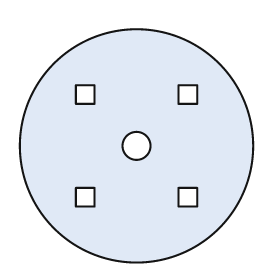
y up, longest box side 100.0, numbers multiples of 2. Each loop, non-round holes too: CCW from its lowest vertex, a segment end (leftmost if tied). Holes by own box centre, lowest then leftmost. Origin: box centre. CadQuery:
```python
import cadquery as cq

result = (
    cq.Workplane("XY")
    .moveTo(0.0, 0.0)
    .circle(50.0)
    .moveTo(-26.0, -26.0)
    .lineTo(-18.0, -26.0)
    .lineTo(-18.0, -18.0)
    .lineTo(-26.0, -18.0)
    .close()
    .moveTo(18.0, -26.0)
    .lineTo(26.0, -26.0)
    .lineTo(26.0, -18.0)
    .lineTo(18.0, -18.0)
    .close()
    .moveTo(0.0, 0.0)
    .circle(6.0)
    .moveTo(-26.0, 18.0)
    .lineTo(-18.0, 18.0)
    .lineTo(-18.0, 26.0)
    .lineTo(-26.0, 26.0)
    .close()
    .moveTo(18.0, 18.0)
    .lineTo(26.0, 18.0)
    .lineTo(26.0, 26.0)
    .lineTo(18.0, 26.0)
    .close()
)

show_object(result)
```